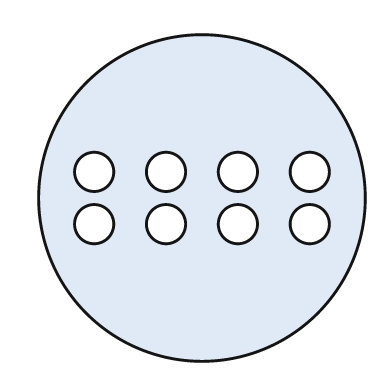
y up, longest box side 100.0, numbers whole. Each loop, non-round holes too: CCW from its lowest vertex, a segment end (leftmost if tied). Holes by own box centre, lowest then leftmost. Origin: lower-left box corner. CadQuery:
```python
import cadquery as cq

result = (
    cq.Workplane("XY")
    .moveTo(50.0, 50.0)
    .circle(50.0)
    .moveTo(17.0, 42.0)
    .circle(6.0)
    .moveTo(39.0, 42.0)
    .circle(6.0)
    .moveTo(61.0, 42.0)
    .circle(6.0)
    .moveTo(83.0, 42.0)
    .circle(6.0)
    .moveTo(17.0, 58.0)
    .circle(6.0)
    .moveTo(39.0, 58.0)
    .circle(6.0)
    .moveTo(61.0, 58.0)
    .circle(6.0)
    .moveTo(83.0, 58.0)
    .circle(6.0)
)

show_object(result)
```